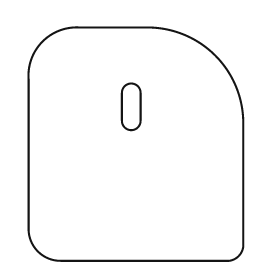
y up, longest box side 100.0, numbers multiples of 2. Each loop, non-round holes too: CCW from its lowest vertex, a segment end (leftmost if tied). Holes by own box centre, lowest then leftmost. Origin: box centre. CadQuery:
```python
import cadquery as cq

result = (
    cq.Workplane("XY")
    .moveTo(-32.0, -50.0)
    .lineTo(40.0, -50.0)
    .threePointArc((44.0, -48.0), (46.0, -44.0))
    .lineTo(46.0, 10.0)
    .threePointArc((34.0, 38.0), (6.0, 50.0))
    .lineTo(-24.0, 50.0)
    .threePointArc((-40.0, 44.0), (-46.0, 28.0))
    .lineTo(-46.0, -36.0)
    .threePointArc((-42.0, -46.0), (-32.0, -50.0))
    .close()
    .moveTo(-6.0, 10.0)
    .threePointArc((-2.0, 6.0), (2.0, 10.0))
    .lineTo(2.0, 22.0)
    .threePointArc((-2.0, 26.0), (-6.0, 22.0))
    .close()
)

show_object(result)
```